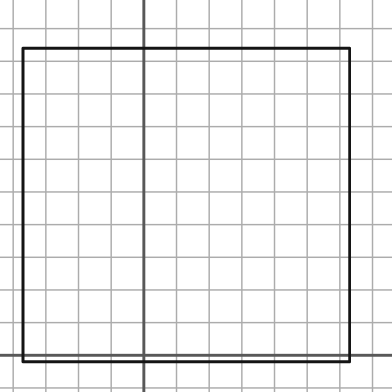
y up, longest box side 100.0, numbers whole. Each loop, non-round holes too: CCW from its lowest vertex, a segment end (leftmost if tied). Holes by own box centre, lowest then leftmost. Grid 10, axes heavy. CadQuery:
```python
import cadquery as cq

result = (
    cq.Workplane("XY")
    .moveTo(-37.0, -2.0)
    .lineTo(63.0, -2.0)
    .lineTo(63.0, 94.0)
    .lineTo(-37.0, 94.0)
    .close()
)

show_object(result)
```